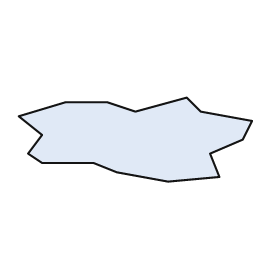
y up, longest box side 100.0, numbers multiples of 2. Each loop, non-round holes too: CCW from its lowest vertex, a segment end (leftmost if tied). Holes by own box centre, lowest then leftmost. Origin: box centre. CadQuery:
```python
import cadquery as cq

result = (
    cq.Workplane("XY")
    .moveTo(14.0, -18.0)
    .lineTo(36.0, -16.0)
    .lineTo(32.0, -6.0)
    .lineTo(46.0, 0.0)
    .lineTo(50.0, 8.0)
    .lineTo(28.0, 12.0)
    .lineTo(22.0, 18.0)
    .lineTo(0.0, 12.0)
    .lineTo(-12.0, 16.0)
    .lineTo(-30.0, 16.0)
    .lineTo(-50.0, 10.0)
    .lineTo(-40.0, 2.0)
    .lineTo(-46.0, -6.0)
    .lineTo(-40.0, -10.0)
    .lineTo(-18.0, -10.0)
    .lineTo(-8.0, -14.0)
    .close()
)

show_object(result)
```